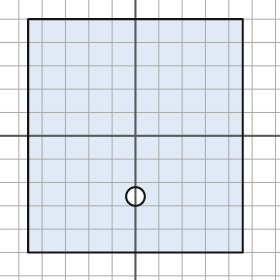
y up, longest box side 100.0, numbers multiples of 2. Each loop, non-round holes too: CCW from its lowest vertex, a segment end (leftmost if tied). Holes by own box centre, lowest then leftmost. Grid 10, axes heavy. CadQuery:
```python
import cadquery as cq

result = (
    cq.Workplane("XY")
    .moveTo(-46.0, -50.0)
    .lineTo(46.0, -50.0)
    .lineTo(46.0, 50.0)
    .lineTo(-46.0, 50.0)
    .close()
    .moveTo(0.0, -26.0)
    .circle(4.0)
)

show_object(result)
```